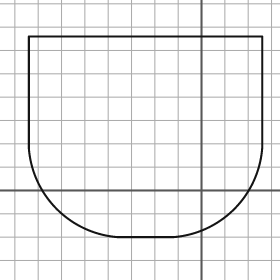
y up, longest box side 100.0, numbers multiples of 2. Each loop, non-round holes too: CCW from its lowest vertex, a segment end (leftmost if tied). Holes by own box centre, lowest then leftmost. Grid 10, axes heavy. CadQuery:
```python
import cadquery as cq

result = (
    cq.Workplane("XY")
    .moveTo(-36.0, -20.0)
    .lineTo(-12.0, -20.0)
    .threePointArc((14.0, -8.0), (26.0, 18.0))
    .lineTo(26.0, 66.0)
    .lineTo(-74.0, 66.0)
    .lineTo(-74.0, 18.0)
    .threePointArc((-62.0, -8.0), (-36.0, -20.0))
    .close()
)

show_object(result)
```